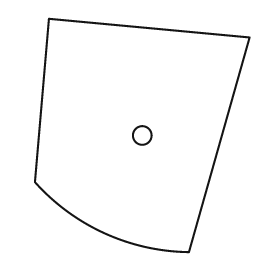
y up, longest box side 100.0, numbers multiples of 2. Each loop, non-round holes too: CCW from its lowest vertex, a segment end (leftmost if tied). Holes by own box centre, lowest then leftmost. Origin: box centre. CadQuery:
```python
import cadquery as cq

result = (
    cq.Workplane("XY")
    .moveTo(20.0, -50.0)
    .lineTo(46.0, 42.0)
    .lineTo(-40.0, 50.0)
    .lineTo(-46.0, -20.0)
    .threePointArc((-16.0, -42.0), (20.0, -50.0))
    .close()
    .moveTo(0.0, 0.0)
    .circle(4.0)
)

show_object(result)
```